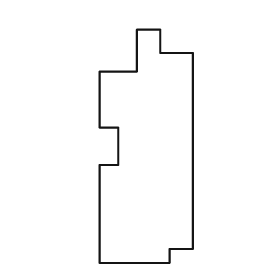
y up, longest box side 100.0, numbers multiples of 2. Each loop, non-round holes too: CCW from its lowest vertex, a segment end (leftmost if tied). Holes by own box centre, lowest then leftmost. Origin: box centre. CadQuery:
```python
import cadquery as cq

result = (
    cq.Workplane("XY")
    .moveTo(-20.0, -50.0)
    .lineTo(10.0, -50.0)
    .lineTo(10.0, -44.0)
    .lineTo(20.0, -44.0)
    .lineTo(20.0, 40.0)
    .lineTo(6.0, 40.0)
    .lineTo(6.0, 50.0)
    .lineTo(-4.0, 50.0)
    .lineTo(-4.0, 32.0)
    .lineTo(-20.0, 32.0)
    .lineTo(-20.0, 8.0)
    .lineTo(-12.0, 8.0)
    .lineTo(-12.0, -8.0)
    .lineTo(-20.0, -8.0)
    .close()
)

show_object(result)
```